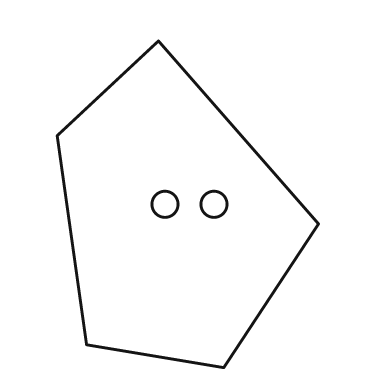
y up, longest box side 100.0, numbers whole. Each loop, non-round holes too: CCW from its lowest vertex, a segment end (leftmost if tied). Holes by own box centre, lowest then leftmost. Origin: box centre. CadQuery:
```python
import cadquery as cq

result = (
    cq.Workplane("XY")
    .moveTo(11.0, -50.0)
    .lineTo(40.0, -6.0)
    .lineTo(-9.0, 50.0)
    .lineTo(-40.0, 21.0)
    .lineTo(-31.0, -43.0)
    .close()
    .moveTo(-7.0, 0.0)
    .circle(4.0)
    .moveTo(8.0, 0.0)
    .circle(4.0)
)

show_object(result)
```